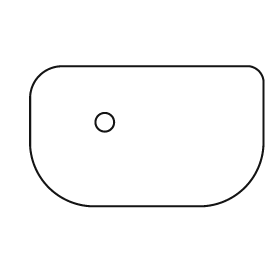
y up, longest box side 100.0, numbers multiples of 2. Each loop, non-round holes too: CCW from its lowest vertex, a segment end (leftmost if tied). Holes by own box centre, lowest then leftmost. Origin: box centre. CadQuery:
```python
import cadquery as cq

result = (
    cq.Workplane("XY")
    .moveTo(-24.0, -30.0)
    .lineTo(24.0, -30.0)
    .threePointArc((42.0, -22.0), (50.0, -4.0))
    .lineTo(50.0, 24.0)
    .threePointArc((48.0, 28.0), (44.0, 30.0))
    .lineTo(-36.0, 30.0)
    .threePointArc((-46.0, 26.0), (-50.0, 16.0))
    .lineTo(-50.0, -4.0)
    .threePointArc((-42.0, -22.0), (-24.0, -30.0))
    .close()
    .moveTo(-18.0, 6.0)
    .circle(4.0)
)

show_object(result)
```